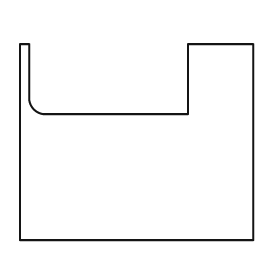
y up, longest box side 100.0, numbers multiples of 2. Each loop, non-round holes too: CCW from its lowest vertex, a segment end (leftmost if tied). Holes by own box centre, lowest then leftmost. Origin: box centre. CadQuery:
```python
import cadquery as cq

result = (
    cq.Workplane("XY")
    .moveTo(-50.0, -42.0)
    .lineTo(50.0, -42.0)
    .lineTo(50.0, 42.0)
    .lineTo(22.0, 42.0)
    .lineTo(22.0, 12.0)
    .lineTo(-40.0, 12.0)
    .threePointArc((-44.0, 14.0), (-46.0, 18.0))
    .lineTo(-46.0, 42.0)
    .lineTo(-50.0, 42.0)
    .close()
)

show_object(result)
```